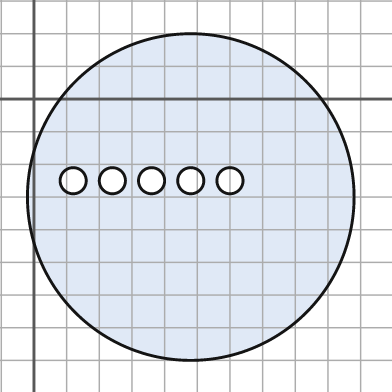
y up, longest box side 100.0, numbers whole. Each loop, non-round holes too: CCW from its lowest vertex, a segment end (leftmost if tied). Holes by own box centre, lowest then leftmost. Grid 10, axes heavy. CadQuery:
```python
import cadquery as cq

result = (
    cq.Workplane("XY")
    .moveTo(48.0, -30.0)
    .circle(50.0)
    .moveTo(12.0, -25.0)
    .circle(4.0)
    .moveTo(24.0, -25.0)
    .circle(4.0)
    .moveTo(36.0, -25.0)
    .circle(4.0)
    .moveTo(48.0, -25.0)
    .circle(4.0)
    .moveTo(60.0, -25.0)
    .circle(4.0)
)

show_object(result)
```